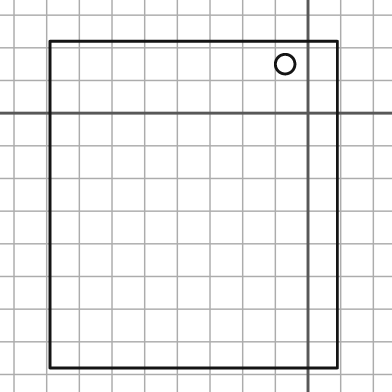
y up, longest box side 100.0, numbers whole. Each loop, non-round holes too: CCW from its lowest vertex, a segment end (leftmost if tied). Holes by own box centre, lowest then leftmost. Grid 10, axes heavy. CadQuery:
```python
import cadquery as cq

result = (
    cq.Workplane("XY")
    .moveTo(-79.0, -78.0)
    .lineTo(9.0, -78.0)
    .lineTo(9.0, 22.0)
    .lineTo(-79.0, 22.0)
    .close()
    .moveTo(-7.0, 15.0)
    .circle(3.0)
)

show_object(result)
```